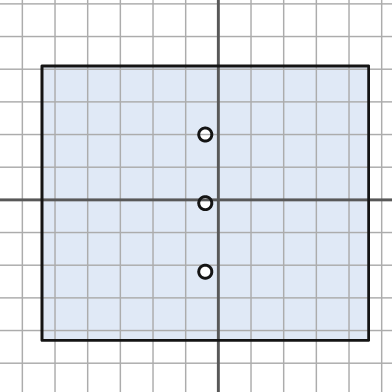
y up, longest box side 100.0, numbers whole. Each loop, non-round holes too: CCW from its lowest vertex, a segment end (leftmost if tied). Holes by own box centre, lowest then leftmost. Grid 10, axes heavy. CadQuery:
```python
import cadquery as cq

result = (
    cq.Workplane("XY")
    .moveTo(-54.0, -43.0)
    .lineTo(46.0, -43.0)
    .lineTo(46.0, 41.0)
    .lineTo(-54.0, 41.0)
    .close()
    .moveTo(-4.0, -22.0)
    .circle(2.0)
    .moveTo(-4.0, -1.0)
    .circle(2.0)
    .moveTo(-4.0, 20.0)
    .circle(2.0)
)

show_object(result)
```